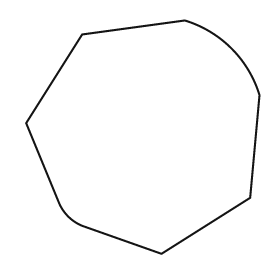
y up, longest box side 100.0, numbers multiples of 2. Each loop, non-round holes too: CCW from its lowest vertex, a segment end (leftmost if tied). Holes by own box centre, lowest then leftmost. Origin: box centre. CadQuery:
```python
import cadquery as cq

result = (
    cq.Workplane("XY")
    .moveTo(8.0, -50.0)
    .lineTo(46.0, -26.0)
    .lineTo(50.0, 18.0)
    .threePointArc((38.0, 38.0), (18.0, 50.0))
    .lineTo(-26.0, 44.0)
    .lineTo(-50.0, 6.0)
    .lineTo(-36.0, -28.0)
    .threePointArc((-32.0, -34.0), (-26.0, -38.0))
    .close()
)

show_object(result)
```